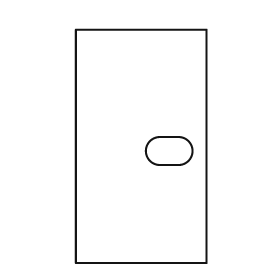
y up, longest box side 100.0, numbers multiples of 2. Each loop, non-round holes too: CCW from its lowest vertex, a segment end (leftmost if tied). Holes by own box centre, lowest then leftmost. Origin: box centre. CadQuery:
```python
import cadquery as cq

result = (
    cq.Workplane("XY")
    .moveTo(-28.0, -50.0)
    .lineTo(28.0, -50.0)
    .lineTo(28.0, 50.0)
    .lineTo(-28.0, 50.0)
    .close()
    .moveTo(8.0, -8.0)
    .lineTo(16.0, -8.0)
    .threePointArc((22.0, -2.0), (16.0, 4.0))
    .lineTo(8.0, 4.0)
    .threePointArc((2.0, -2.0), (8.0, -8.0))
    .close()
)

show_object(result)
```